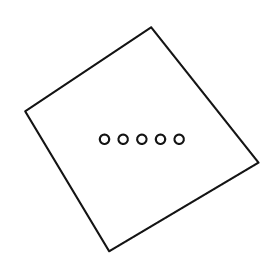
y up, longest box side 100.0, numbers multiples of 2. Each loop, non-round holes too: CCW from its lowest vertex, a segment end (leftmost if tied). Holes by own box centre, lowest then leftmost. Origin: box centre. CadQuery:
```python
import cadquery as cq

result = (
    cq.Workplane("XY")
    .moveTo(-14.0, -48.0)
    .lineTo(50.0, -10.0)
    .lineTo(4.0, 48.0)
    .lineTo(-50.0, 12.0)
    .close()
    .moveTo(-16.0, 0.0)
    .circle(2.0)
    .moveTo(-8.0, 0.0)
    .circle(2.0)
    .moveTo(0.0, 0.0)
    .circle(2.0)
    .moveTo(8.0, 0.0)
    .circle(2.0)
    .moveTo(16.0, 0.0)
    .circle(2.0)
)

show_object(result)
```